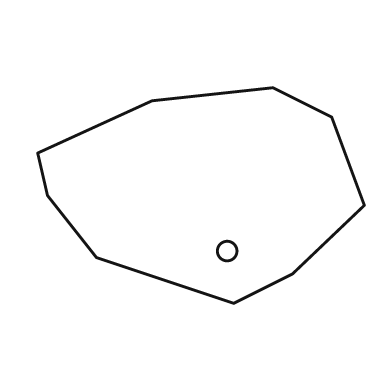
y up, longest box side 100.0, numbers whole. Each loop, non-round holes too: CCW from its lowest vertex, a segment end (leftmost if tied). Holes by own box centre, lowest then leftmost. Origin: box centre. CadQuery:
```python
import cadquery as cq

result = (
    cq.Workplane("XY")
    .moveTo(10.0, -33.0)
    .lineTo(28.0, -24.0)
    .lineTo(50.0, -3.0)
    .lineTo(40.0, 24.0)
    .lineTo(22.0, 33.0)
    .lineTo(-15.0, 29.0)
    .lineTo(-50.0, 13.0)
    .lineTo(-47.0, 0.0)
    .lineTo(-32.0, -19.0)
    .close()
    .moveTo(8.0, -17.0)
    .circle(3.0)
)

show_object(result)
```